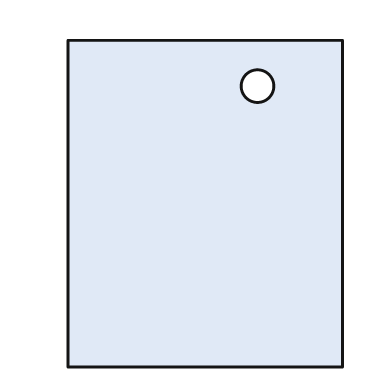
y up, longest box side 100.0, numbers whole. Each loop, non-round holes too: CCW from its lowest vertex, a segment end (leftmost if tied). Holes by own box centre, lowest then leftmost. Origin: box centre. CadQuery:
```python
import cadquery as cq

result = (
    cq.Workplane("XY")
    .moveTo(-42.0, -50.0)
    .lineTo(42.0, -50.0)
    .lineTo(42.0, 50.0)
    .lineTo(-42.0, 50.0)
    .close()
    .moveTo(16.0, 36.0)
    .circle(5.0)
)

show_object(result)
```